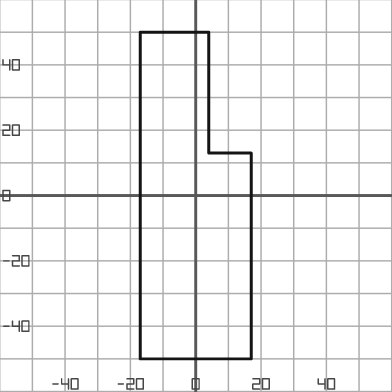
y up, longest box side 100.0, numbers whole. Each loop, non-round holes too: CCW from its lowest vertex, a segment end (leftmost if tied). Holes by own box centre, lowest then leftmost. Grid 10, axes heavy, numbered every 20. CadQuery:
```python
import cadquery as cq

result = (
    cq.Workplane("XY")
    .moveTo(-17.0, -50.0)
    .lineTo(17.0, -50.0)
    .lineTo(17.0, 13.0)
    .lineTo(4.0, 13.0)
    .lineTo(4.0, 50.0)
    .lineTo(-17.0, 50.0)
    .close()
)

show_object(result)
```